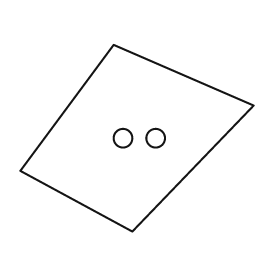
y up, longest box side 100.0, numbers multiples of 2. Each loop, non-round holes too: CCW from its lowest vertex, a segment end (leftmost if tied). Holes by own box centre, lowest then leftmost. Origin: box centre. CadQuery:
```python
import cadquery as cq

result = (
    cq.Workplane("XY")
    .moveTo(-2.0, -40.0)
    .lineTo(50.0, 14.0)
    .lineTo(-10.0, 40.0)
    .lineTo(-50.0, -14.0)
    .close()
    .moveTo(-6.0, 0.0)
    .circle(4.0)
    .moveTo(8.0, 0.0)
    .circle(4.0)
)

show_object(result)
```